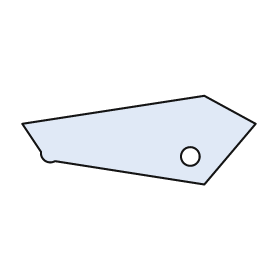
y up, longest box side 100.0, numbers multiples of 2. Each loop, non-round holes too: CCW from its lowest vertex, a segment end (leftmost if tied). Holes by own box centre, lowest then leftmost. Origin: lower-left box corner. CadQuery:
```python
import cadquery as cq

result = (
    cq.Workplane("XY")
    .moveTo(78.0, 0.0)
    .lineTo(100.0, 26.0)
    .lineTo(78.0, 38.0)
    .lineTo(0.0, 26.0)
    .lineTo(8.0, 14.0)
    .threePointArc((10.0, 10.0), (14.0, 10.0))
    .close()
    .moveTo(72.0, 12.0)
    .circle(4.0)
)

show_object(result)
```